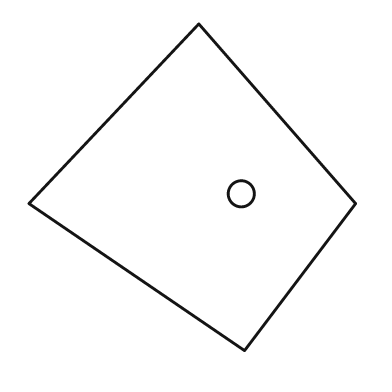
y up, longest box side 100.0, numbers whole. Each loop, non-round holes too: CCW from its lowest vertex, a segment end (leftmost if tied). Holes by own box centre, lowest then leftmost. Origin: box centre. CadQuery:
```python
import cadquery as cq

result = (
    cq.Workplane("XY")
    .moveTo(16.0, -50.0)
    .lineTo(50.0, -5.0)
    .lineTo(2.0, 50.0)
    .lineTo(-50.0, -5.0)
    .close()
    .moveTo(15.0, -2.0)
    .circle(4.0)
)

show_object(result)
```